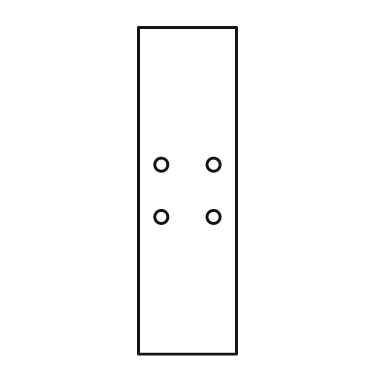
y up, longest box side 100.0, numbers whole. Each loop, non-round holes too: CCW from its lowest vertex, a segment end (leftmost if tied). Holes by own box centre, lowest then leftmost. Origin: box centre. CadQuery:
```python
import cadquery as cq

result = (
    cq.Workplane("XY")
    .moveTo(-15.0, -50.0)
    .lineTo(15.0, -50.0)
    .lineTo(15.0, 50.0)
    .lineTo(-15.0, 50.0)
    .close()
    .moveTo(-8.0, -8.0)
    .circle(2.0)
    .moveTo(8.0, -8.0)
    .circle(2.0)
    .moveTo(-8.0, 8.0)
    .circle(2.0)
    .moveTo(8.0, 8.0)
    .circle(2.0)
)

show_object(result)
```